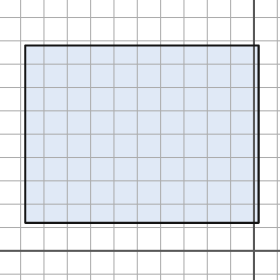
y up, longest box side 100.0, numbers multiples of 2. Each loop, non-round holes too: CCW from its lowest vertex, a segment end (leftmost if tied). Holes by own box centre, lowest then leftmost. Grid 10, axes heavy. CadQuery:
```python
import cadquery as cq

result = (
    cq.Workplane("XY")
    .moveTo(-98.0, 12.0)
    .lineTo(2.0, 12.0)
    .lineTo(2.0, 88.0)
    .lineTo(-98.0, 88.0)
    .close()
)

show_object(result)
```